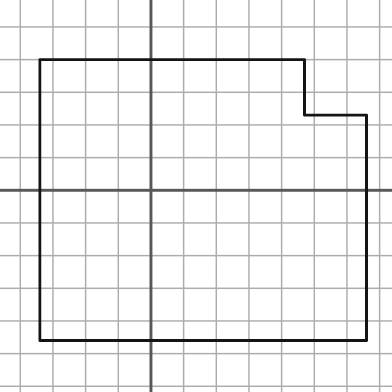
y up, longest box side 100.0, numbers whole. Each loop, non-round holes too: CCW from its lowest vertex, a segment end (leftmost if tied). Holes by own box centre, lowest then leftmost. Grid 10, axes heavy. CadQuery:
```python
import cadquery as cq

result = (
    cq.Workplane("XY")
    .moveTo(-34.0, -46.0)
    .lineTo(66.0, -46.0)
    .lineTo(66.0, 23.0)
    .lineTo(47.0, 23.0)
    .lineTo(47.0, 40.0)
    .lineTo(-34.0, 40.0)
    .close()
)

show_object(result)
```